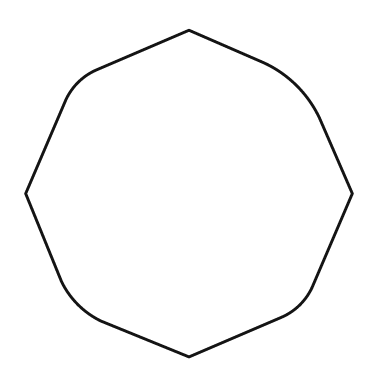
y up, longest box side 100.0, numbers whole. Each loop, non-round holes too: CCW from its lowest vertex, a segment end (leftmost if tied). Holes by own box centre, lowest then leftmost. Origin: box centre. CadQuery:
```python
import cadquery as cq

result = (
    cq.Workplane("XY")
    .moveTo(0.0, -50.0)
    .lineTo(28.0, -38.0)
    .threePointArc((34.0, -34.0), (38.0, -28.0))
    .lineTo(50.0, 0.0)
    .lineTo(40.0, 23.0)
    .threePointArc((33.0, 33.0), (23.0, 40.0))
    .lineTo(0.0, 50.0)
    .lineTo(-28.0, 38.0)
    .threePointArc((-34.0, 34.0), (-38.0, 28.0))
    .lineTo(-50.0, 0.0)
    .lineTo(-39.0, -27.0)
    .threePointArc((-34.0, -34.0), (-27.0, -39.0))
    .close()
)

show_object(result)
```